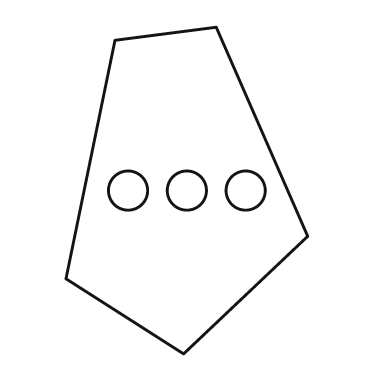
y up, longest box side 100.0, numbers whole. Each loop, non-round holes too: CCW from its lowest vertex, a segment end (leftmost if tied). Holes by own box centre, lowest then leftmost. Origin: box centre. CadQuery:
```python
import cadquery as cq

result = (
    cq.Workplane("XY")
    .moveTo(-1.0, -50.0)
    .lineTo(37.0, -14.0)
    .lineTo(9.0, 50.0)
    .lineTo(-22.0, 46.0)
    .lineTo(-37.0, -27.0)
    .close()
    .moveTo(-18.0, 0.0)
    .circle(6.0)
    .moveTo(0.0, 0.0)
    .circle(6.0)
    .moveTo(18.0, 0.0)
    .circle(6.0)
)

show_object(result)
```